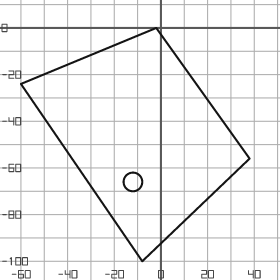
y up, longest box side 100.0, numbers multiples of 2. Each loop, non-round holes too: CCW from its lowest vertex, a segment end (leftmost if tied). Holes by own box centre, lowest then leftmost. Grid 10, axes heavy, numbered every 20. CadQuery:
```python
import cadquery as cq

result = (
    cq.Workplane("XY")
    .moveTo(-8.0, -100.0)
    .lineTo(38.0, -56.0)
    .lineTo(-2.0, 0.0)
    .lineTo(-60.0, -24.0)
    .close()
    .moveTo(-12.0, -66.0)
    .circle(4.0)
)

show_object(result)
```